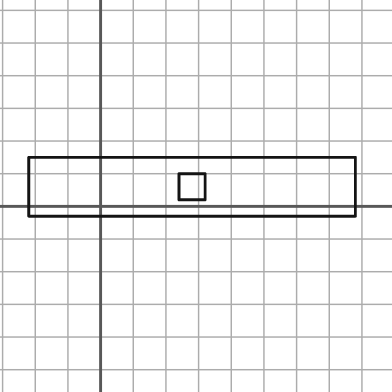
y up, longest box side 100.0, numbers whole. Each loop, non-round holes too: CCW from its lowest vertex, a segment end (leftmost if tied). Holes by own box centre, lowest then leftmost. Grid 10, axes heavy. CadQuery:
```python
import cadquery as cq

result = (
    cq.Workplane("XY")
    .moveTo(-22.0, -3.0)
    .lineTo(78.0, -3.0)
    .lineTo(78.0, 15.0)
    .lineTo(-22.0, 15.0)
    .close()
    .moveTo(24.0, 2.0)
    .lineTo(32.0, 2.0)
    .lineTo(32.0, 10.0)
    .lineTo(24.0, 10.0)
    .close()
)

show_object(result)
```